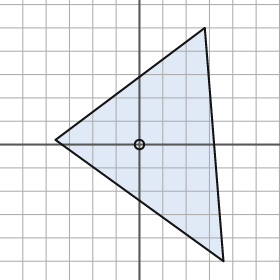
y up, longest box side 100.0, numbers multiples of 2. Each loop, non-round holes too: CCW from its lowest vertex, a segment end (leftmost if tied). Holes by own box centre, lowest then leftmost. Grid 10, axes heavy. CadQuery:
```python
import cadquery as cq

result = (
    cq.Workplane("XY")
    .moveTo(36.0, -50.0)
    .lineTo(28.0, 50.0)
    .lineTo(-36.0, 2.0)
    .close()
    .moveTo(0.0, 0.0)
    .circle(2.0)
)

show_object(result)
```